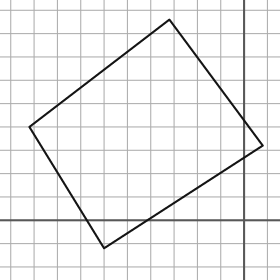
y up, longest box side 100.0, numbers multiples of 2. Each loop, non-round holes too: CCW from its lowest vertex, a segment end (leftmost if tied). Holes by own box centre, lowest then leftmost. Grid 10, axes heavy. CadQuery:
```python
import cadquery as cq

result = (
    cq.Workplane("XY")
    .moveTo(-60.0, -12.0)
    .lineTo(8.0, 32.0)
    .lineTo(-32.0, 86.0)
    .lineTo(-92.0, 40.0)
    .close()
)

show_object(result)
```